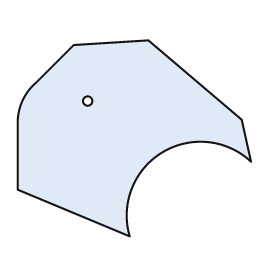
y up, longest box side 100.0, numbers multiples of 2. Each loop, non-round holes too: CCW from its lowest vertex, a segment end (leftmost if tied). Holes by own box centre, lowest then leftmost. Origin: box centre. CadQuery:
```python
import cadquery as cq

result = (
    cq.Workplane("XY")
    .moveTo(-2.0, -42.0)
    .threePointArc((12.0, -6.0), (50.0, -10.0))
    .lineTo(46.0, 8.0)
    .lineTo(6.0, 42.0)
    .lineTo(-26.0, 40.0)
    .lineTo(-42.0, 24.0)
    .threePointArc((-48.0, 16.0), (-50.0, 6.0))
    .lineTo(-50.0, -22.0)
    .close()
    .moveTo(-20.0, 16.0)
    .circle(2.0)
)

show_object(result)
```